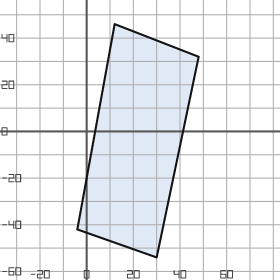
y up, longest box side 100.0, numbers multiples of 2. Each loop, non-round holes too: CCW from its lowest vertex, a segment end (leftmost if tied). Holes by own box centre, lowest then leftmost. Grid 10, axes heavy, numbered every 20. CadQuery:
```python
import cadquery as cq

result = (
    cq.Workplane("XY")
    .moveTo(30.0, -54.0)
    .lineTo(48.0, 32.0)
    .lineTo(12.0, 46.0)
    .lineTo(-4.0, -42.0)
    .close()
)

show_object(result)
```